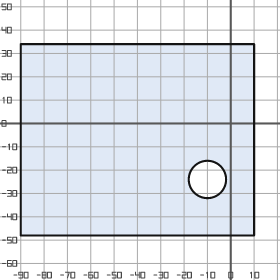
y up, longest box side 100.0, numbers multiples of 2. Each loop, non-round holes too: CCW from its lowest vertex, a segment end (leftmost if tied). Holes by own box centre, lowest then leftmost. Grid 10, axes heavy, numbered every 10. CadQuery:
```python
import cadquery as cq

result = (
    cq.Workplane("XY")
    .moveTo(-90.0, -48.0)
    .lineTo(10.0, -48.0)
    .lineTo(10.0, 34.0)
    .lineTo(-90.0, 34.0)
    .close()
    .moveTo(-10.0, -24.0)
    .circle(8.0)
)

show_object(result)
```